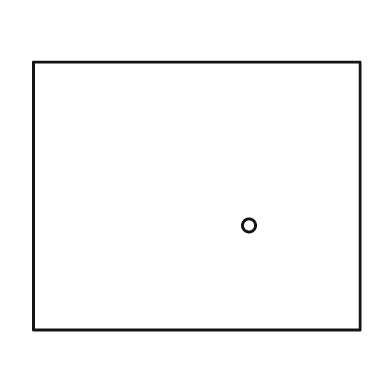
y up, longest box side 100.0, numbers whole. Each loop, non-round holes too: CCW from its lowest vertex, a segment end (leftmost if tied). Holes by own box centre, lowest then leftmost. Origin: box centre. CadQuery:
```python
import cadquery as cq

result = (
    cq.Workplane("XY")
    .moveTo(-50.0, -41.0)
    .lineTo(50.0, -41.0)
    .lineTo(50.0, 41.0)
    .lineTo(-50.0, 41.0)
    .close()
    .moveTo(16.0, -9.0)
    .circle(2.0)
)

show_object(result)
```